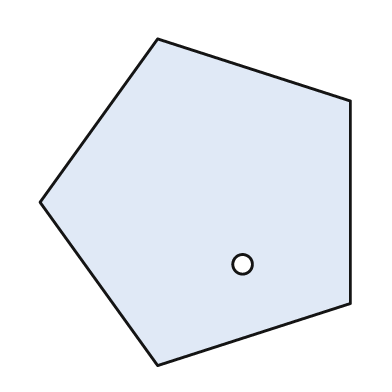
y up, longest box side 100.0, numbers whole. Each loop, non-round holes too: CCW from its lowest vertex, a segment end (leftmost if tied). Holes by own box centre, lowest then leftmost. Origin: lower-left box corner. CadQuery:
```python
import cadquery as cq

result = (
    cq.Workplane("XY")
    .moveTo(36.0, 0.0)
    .lineTo(95.0, 19.0)
    .lineTo(95.0, 81.0)
    .lineTo(36.0, 100.0)
    .lineTo(0.0, 50.0)
    .close()
    .moveTo(62.0, 31.0)
    .circle(3.0)
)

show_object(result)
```